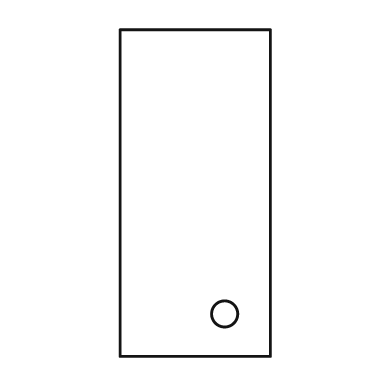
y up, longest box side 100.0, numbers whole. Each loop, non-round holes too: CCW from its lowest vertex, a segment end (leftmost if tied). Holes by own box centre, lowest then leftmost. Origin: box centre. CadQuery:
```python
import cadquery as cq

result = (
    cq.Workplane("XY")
    .moveTo(-23.0, -50.0)
    .lineTo(23.0, -50.0)
    .lineTo(23.0, 50.0)
    .lineTo(-23.0, 50.0)
    .close()
    .moveTo(9.0, -37.0)
    .circle(4.0)
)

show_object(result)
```